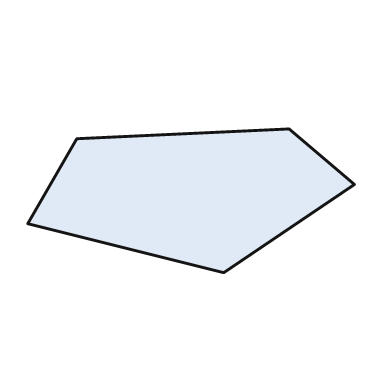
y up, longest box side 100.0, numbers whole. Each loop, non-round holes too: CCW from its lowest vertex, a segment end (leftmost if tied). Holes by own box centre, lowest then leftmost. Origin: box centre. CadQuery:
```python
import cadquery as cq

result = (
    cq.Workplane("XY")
    .moveTo(10.0, -22.0)
    .lineTo(50.0, 5.0)
    .lineTo(30.0, 22.0)
    .lineTo(-35.0, 19.0)
    .lineTo(-50.0, -7.0)
    .close()
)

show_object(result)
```